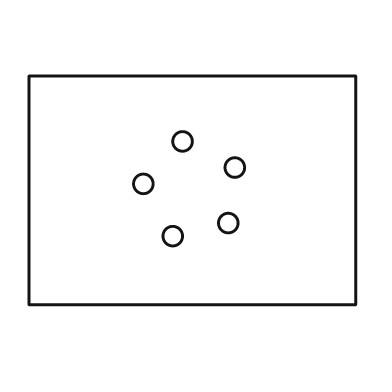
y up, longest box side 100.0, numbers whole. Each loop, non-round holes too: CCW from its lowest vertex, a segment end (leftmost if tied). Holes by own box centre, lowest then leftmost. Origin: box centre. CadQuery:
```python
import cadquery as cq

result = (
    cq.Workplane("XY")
    .moveTo(-50.0, -35.0)
    .lineTo(50.0, -35.0)
    .lineTo(50.0, 35.0)
    .lineTo(-50.0, 35.0)
    .close()
    .moveTo(-6.0, -14.0)
    .circle(3.0)
    .moveTo(11.0, -10.0)
    .circle(3.0)
    .moveTo(-15.0, 2.0)
    .circle(3.0)
    .moveTo(13.0, 7.0)
    .circle(3.0)
    .moveTo(-3.0, 15.0)
    .circle(3.0)
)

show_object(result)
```